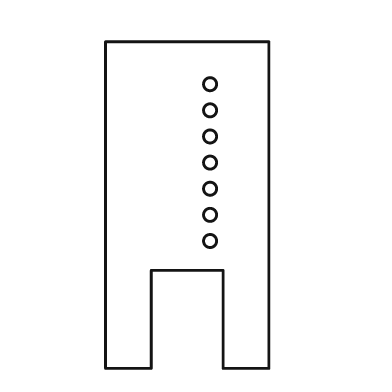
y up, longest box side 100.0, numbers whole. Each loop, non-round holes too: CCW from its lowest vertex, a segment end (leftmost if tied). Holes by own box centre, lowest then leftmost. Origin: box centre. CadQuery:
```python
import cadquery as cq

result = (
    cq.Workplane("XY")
    .moveTo(-25.0, -50.0)
    .lineTo(-11.0, -50.0)
    .lineTo(-11.0, -20.0)
    .lineTo(11.0, -20.0)
    .lineTo(11.0, -50.0)
    .lineTo(25.0, -50.0)
    .lineTo(25.0, 50.0)
    .lineTo(-25.0, 50.0)
    .close()
    .moveTo(7.0, -11.0)
    .circle(2.0)
    .moveTo(7.0, -3.0)
    .circle(2.0)
    .moveTo(7.0, 5.0)
    .circle(2.0)
    .moveTo(7.0, 13.0)
    .circle(2.0)
    .moveTo(7.0, 21.0)
    .circle(2.0)
    .moveTo(7.0, 29.0)
    .circle(2.0)
    .moveTo(7.0, 37.0)
    .circle(2.0)
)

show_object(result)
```